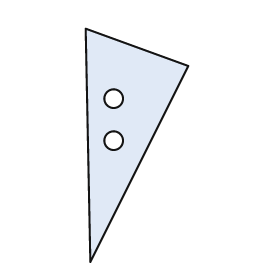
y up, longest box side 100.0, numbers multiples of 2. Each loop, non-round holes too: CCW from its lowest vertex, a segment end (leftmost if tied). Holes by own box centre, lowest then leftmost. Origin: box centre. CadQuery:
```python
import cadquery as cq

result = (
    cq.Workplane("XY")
    .moveTo(-20.0, -50.0)
    .lineTo(22.0, 34.0)
    .lineTo(-22.0, 50.0)
    .close()
    .moveTo(-10.0, 2.0)
    .circle(4.0)
    .moveTo(-10.0, 20.0)
    .circle(4.0)
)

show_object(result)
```